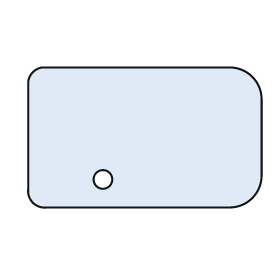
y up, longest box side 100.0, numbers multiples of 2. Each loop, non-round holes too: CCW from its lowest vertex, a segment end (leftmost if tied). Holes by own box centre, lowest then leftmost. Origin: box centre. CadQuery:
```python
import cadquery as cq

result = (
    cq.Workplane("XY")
    .moveTo(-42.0, -30.0)
    .lineTo(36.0, -30.0)
    .threePointArc((46.0, -26.0), (50.0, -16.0))
    .lineTo(50.0, 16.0)
    .threePointArc((46.0, 26.0), (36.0, 30.0))
    .lineTo(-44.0, 30.0)
    .threePointArc((-48.0, 28.0), (-50.0, 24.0))
    .lineTo(-50.0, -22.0)
    .threePointArc((-48.0, -28.0), (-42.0, -30.0))
    .close()
    .moveTo(-18.0, -18.0)
    .circle(4.0)
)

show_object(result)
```